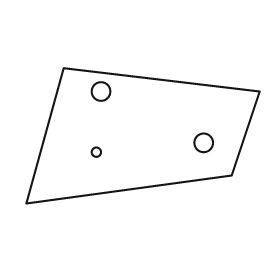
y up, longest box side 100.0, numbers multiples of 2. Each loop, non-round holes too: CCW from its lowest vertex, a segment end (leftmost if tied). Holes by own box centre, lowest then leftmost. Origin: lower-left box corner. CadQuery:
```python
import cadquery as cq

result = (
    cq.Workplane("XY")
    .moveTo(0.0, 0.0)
    .lineTo(88.0, 12.0)
    .lineTo(100.0, 48.0)
    .lineTo(16.0, 58.0)
    .close()
    .moveTo(30.0, 22.0)
    .circle(2.0)
    .moveTo(76.0, 26.0)
    .circle(4.0)
    .moveTo(32.0, 48.0)
    .circle(4.0)
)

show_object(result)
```